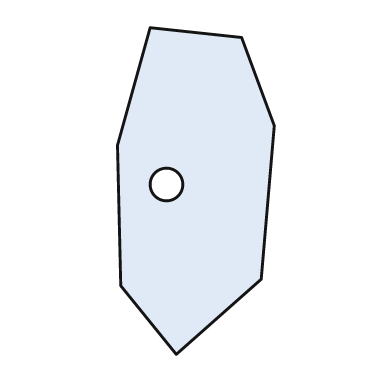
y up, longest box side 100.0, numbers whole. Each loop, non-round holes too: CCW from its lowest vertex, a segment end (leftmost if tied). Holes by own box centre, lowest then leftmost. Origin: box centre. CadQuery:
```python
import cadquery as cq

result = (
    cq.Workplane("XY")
    .moveTo(-6.0, -50.0)
    .lineTo(20.0, -27.0)
    .lineTo(24.0, 20.0)
    .lineTo(14.0, 47.0)
    .lineTo(-14.0, 50.0)
    .lineTo(-24.0, 14.0)
    .lineTo(-23.0, -29.0)
    .close()
    .moveTo(-9.0, 2.0)
    .circle(5.0)
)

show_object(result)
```